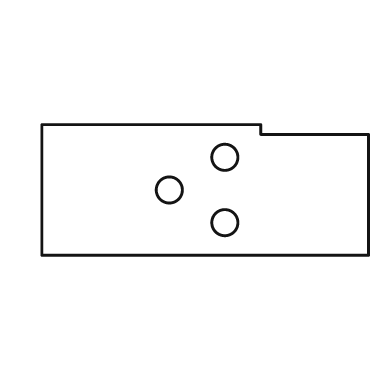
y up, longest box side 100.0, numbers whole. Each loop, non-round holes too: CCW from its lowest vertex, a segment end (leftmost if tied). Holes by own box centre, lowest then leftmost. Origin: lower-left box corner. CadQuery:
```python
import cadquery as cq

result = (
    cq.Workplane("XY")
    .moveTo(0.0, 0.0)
    .lineTo(100.0, 0.0)
    .lineTo(100.0, 37.0)
    .lineTo(67.0, 37.0)
    .lineTo(67.0, 40.0)
    .lineTo(0.0, 40.0)
    .close()
    .moveTo(56.0, 10.0)
    .circle(4.0)
    .moveTo(39.0, 20.0)
    .circle(4.0)
    .moveTo(56.0, 30.0)
    .circle(4.0)
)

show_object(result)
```